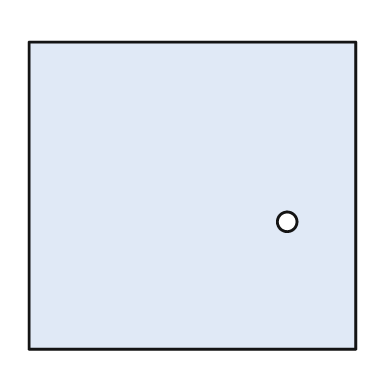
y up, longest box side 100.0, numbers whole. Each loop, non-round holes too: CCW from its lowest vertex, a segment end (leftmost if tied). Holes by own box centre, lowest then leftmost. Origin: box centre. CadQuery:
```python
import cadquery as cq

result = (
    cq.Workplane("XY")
    .moveTo(-50.0, -47.0)
    .lineTo(50.0, -47.0)
    .lineTo(50.0, 47.0)
    .lineTo(-50.0, 47.0)
    .close()
    .moveTo(29.0, -8.0)
    .circle(3.0)
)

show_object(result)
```